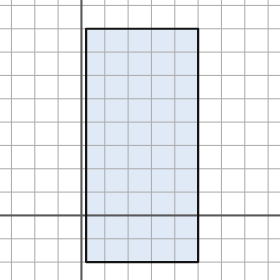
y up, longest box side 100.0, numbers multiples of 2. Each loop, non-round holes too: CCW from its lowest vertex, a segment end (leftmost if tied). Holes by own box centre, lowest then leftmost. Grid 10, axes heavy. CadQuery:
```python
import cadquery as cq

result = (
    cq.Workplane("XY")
    .moveTo(2.0, -20.0)
    .lineTo(50.0, -20.0)
    .lineTo(50.0, 80.0)
    .lineTo(2.0, 80.0)
    .close()
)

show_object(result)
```